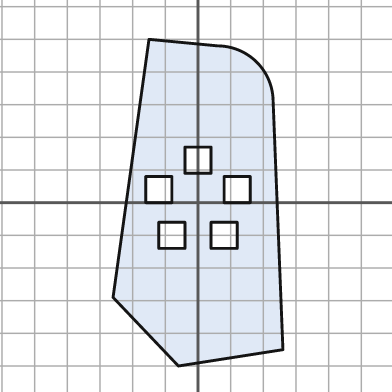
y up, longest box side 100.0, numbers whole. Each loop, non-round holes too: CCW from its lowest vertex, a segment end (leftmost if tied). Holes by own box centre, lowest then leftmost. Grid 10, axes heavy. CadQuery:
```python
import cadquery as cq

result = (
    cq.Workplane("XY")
    .moveTo(-6.0, -50.0)
    .lineTo(26.0, -45.0)
    .lineTo(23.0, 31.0)
    .threePointArc((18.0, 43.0), (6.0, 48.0))
    .lineTo(-15.0, 50.0)
    .lineTo(-26.0, -29.0)
    .close()
    .moveTo(-12.0, -14.0)
    .lineTo(-4.0, -14.0)
    .lineTo(-4.0, -6.0)
    .lineTo(-12.0, -6.0)
    .close()
    .moveTo(4.0, -14.0)
    .lineTo(12.0, -14.0)
    .lineTo(12.0, -6.0)
    .lineTo(4.0, -6.0)
    .close()
    .moveTo(-16.0, 0.0)
    .lineTo(-8.0, 0.0)
    .lineTo(-8.0, 8.0)
    .lineTo(-16.0, 8.0)
    .close()
    .moveTo(8.0, 0.0)
    .lineTo(16.0, 0.0)
    .lineTo(16.0, 8.0)
    .lineTo(8.0, 8.0)
    .close()
    .moveTo(-4.0, 9.0)
    .lineTo(4.0, 9.0)
    .lineTo(4.0, 17.0)
    .lineTo(-4.0, 17.0)
    .close()
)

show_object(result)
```